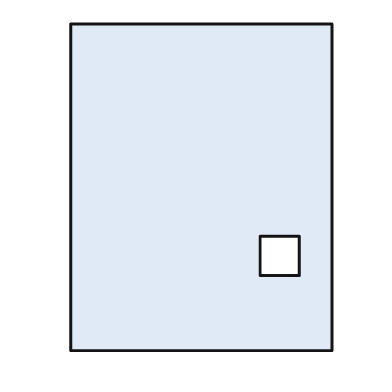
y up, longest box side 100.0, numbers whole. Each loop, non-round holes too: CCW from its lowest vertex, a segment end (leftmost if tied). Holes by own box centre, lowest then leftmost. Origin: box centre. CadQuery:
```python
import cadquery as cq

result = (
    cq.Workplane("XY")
    .moveTo(-40.0, -50.0)
    .lineTo(40.0, -50.0)
    .lineTo(40.0, 50.0)
    .lineTo(-40.0, 50.0)
    .close()
    .moveTo(18.0, -27.0)
    .lineTo(30.0, -27.0)
    .lineTo(30.0, -15.0)
    .lineTo(18.0, -15.0)
    .close()
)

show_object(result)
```